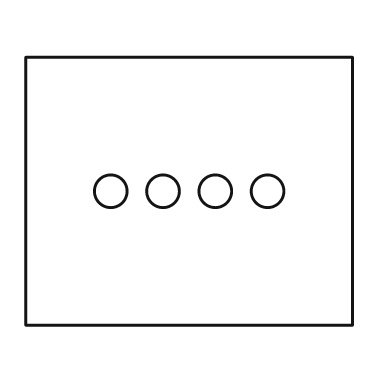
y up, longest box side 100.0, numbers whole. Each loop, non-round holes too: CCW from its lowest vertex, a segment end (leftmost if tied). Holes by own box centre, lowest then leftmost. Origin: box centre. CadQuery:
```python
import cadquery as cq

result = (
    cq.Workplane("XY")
    .moveTo(-50.0, -41.0)
    .lineTo(50.0, -41.0)
    .lineTo(50.0, 41.0)
    .lineTo(-50.0, 41.0)
    .close()
    .moveTo(-24.0, 0.0)
    .circle(5.0)
    .moveTo(-8.0, 0.0)
    .circle(5.0)
    .moveTo(8.0, 0.0)
    .circle(5.0)
    .moveTo(24.0, 0.0)
    .circle(5.0)
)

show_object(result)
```